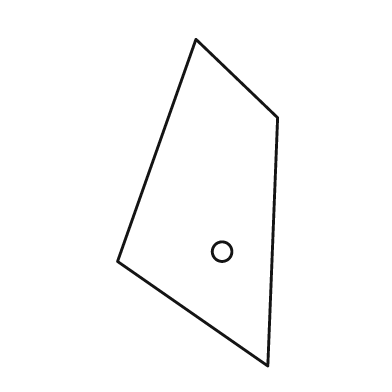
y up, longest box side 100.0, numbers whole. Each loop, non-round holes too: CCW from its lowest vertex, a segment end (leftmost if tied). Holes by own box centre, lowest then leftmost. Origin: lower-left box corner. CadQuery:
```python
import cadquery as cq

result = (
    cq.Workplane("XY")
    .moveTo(46.0, 0.0)
    .lineTo(49.0, 76.0)
    .lineTo(24.0, 100.0)
    .lineTo(0.0, 32.0)
    .close()
    .moveTo(32.0, 35.0)
    .circle(3.0)
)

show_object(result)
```